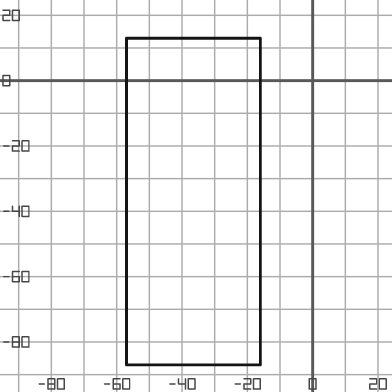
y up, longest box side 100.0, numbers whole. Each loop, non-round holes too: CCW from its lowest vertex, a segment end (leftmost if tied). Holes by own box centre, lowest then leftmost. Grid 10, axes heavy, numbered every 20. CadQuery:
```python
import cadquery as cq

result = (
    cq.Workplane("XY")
    .moveTo(-57.0, -87.0)
    .lineTo(-16.0, -87.0)
    .lineTo(-16.0, 13.0)
    .lineTo(-57.0, 13.0)
    .close()
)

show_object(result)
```